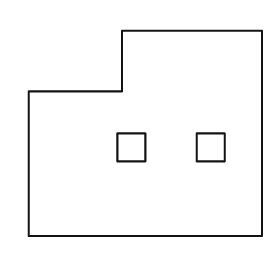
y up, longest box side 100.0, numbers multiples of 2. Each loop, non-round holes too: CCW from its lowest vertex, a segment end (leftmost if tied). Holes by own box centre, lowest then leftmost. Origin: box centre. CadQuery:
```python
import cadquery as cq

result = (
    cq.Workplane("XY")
    .moveTo(-50.0, -44.0)
    .lineTo(50.0, -44.0)
    .lineTo(50.0, 44.0)
    .lineTo(-10.0, 44.0)
    .lineTo(-10.0, 18.0)
    .lineTo(-50.0, 18.0)
    .close()
    .moveTo(-12.0, -12.0)
    .lineTo(0.0, -12.0)
    .lineTo(0.0, 0.0)
    .lineTo(-12.0, 0.0)
    .close()
    .moveTo(22.0, -12.0)
    .lineTo(34.0, -12.0)
    .lineTo(34.0, 0.0)
    .lineTo(22.0, 0.0)
    .close()
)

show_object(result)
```